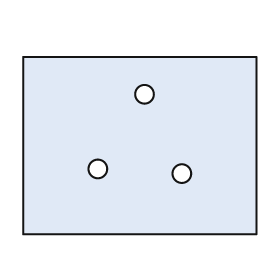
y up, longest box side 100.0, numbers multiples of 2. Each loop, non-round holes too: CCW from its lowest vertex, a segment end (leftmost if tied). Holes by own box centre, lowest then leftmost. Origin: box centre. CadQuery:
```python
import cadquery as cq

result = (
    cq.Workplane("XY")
    .moveTo(-50.0, -38.0)
    .lineTo(50.0, -38.0)
    .lineTo(50.0, 38.0)
    .lineTo(-50.0, 38.0)
    .close()
    .moveTo(18.0, -12.0)
    .circle(4.0)
    .moveTo(-18.0, -10.0)
    .circle(4.0)
    .moveTo(2.0, 22.0)
    .circle(4.0)
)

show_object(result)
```